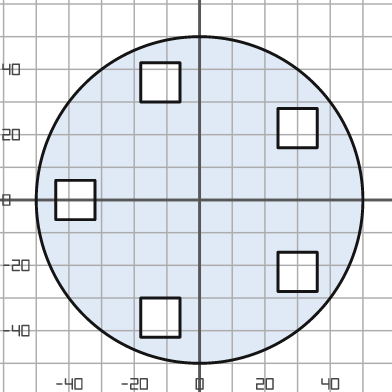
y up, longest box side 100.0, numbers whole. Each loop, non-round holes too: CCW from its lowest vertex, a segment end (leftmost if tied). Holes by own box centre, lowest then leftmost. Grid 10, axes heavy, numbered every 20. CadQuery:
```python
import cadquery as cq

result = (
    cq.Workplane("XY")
    .moveTo(0.0, 0.0)
    .circle(50.0)
    .moveTo(-18.0, -42.0)
    .lineTo(-6.0, -42.0)
    .lineTo(-6.0, -30.0)
    .lineTo(-18.0, -30.0)
    .close()
    .moveTo(24.0, -28.0)
    .lineTo(36.0, -28.0)
    .lineTo(36.0, -16.0)
    .lineTo(24.0, -16.0)
    .close()
    .moveTo(-44.0, -6.0)
    .lineTo(-32.0, -6.0)
    .lineTo(-32.0, 6.0)
    .lineTo(-44.0, 6.0)
    .close()
    .moveTo(24.0, 16.0)
    .lineTo(36.0, 16.0)
    .lineTo(36.0, 28.0)
    .lineTo(24.0, 28.0)
    .close()
    .moveTo(-18.0, 30.0)
    .lineTo(-6.0, 30.0)
    .lineTo(-6.0, 42.0)
    .lineTo(-18.0, 42.0)
    .close()
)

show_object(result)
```